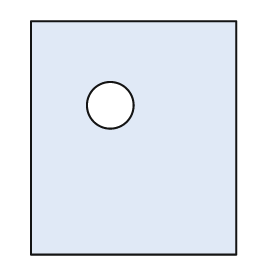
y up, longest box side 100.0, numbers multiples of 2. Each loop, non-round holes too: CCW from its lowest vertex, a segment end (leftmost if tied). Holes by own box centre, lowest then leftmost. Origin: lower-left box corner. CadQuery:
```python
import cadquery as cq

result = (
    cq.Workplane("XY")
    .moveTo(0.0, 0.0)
    .lineTo(88.0, 0.0)
    .lineTo(88.0, 100.0)
    .lineTo(0.0, 100.0)
    .close()
    .moveTo(34.0, 64.0)
    .circle(10.0)
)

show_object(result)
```